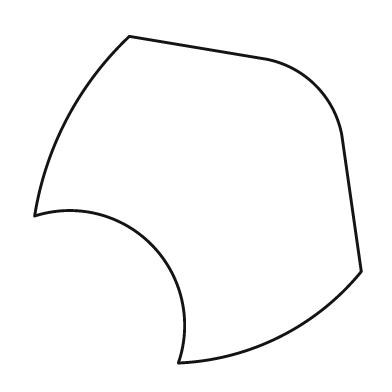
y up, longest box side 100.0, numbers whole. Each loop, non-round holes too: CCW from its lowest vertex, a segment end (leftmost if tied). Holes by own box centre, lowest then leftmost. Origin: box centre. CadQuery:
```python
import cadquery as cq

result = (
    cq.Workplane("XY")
    .moveTo(-6.0, -50.0)
    .threePointArc((25.0, -42.0), (50.0, -22.0))
    .lineTo(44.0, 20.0)
    .threePointArc((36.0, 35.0), (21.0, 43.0))
    .lineTo(-21.0, 50.0)
    .threePointArc((-40.0, 25.0), (-50.0, -5.0))
    .threePointArc((-14.0, -14.0), (-6.0, -50.0))
    .close()
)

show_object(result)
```